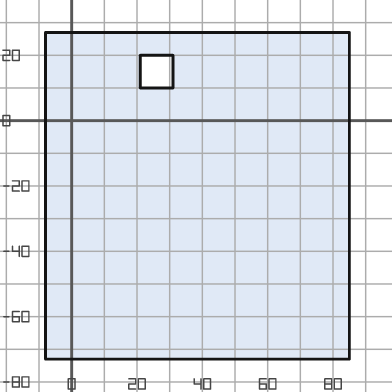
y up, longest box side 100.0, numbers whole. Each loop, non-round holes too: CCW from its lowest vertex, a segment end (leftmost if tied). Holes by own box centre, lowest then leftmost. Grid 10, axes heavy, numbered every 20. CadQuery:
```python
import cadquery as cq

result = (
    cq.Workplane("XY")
    .moveTo(-8.0, -73.0)
    .lineTo(85.0, -73.0)
    .lineTo(85.0, 27.0)
    .lineTo(-8.0, 27.0)
    .close()
    .moveTo(21.0, 10.0)
    .lineTo(31.0, 10.0)
    .lineTo(31.0, 20.0)
    .lineTo(21.0, 20.0)
    .close()
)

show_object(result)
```